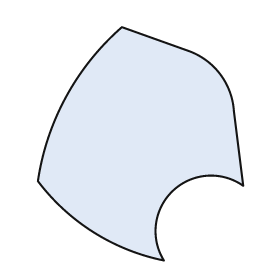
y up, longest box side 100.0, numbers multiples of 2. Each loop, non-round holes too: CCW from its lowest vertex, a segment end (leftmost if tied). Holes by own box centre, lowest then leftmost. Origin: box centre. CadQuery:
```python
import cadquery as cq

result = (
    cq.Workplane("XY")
    .moveTo(10.0, -50.0)
    .threePointArc((14.0, -20.0), (44.0, -18.0))
    .lineTo(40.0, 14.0)
    .threePointArc((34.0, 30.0), (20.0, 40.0))
    .lineTo(-8.0, 50.0)
    .threePointArc((-32.0, 20.0), (-44.0, -16.0))
    .threePointArc((-20.0, -38.0), (10.0, -50.0))
    .close()
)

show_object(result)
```